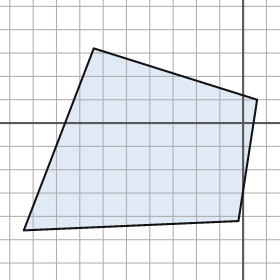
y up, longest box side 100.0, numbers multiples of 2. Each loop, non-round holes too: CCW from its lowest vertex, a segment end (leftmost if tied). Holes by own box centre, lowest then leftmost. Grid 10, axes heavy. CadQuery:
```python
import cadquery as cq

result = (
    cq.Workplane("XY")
    .moveTo(-94.0, -46.0)
    .lineTo(-2.0, -42.0)
    .lineTo(6.0, 10.0)
    .lineTo(-64.0, 32.0)
    .close()
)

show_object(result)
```